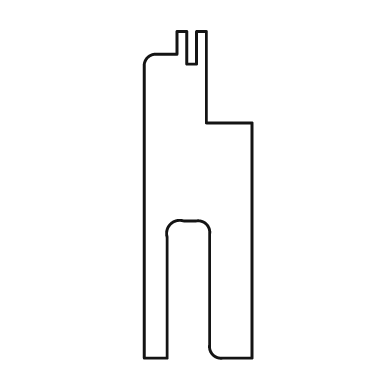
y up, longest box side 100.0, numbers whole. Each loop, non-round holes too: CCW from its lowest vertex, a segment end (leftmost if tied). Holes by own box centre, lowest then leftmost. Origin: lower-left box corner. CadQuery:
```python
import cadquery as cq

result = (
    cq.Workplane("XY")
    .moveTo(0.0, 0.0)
    .lineTo(7.0, 0.0)
    .lineTo(7.0, 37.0)
    .threePointArc((8.0, 41.0), (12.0, 42.0))
    .lineTo(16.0, 42.0)
    .threePointArc((19.0, 41.0), (20.0, 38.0))
    .lineTo(20.0, 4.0)
    .threePointArc((21.0, 1.0), (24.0, 0.0))
    .lineTo(33.0, 0.0)
    .lineTo(33.0, 72.0)
    .lineTo(19.0, 72.0)
    .lineTo(19.0, 100.0)
    .lineTo(16.0, 100.0)
    .lineTo(16.0, 90.0)
    .lineTo(13.0, 90.0)
    .lineTo(13.0, 100.0)
    .lineTo(10.0, 100.0)
    .lineTo(10.0, 93.0)
    .lineTo(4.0, 93.0)
    .threePointArc((1.0, 92.0), (0.0, 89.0))
    .close()
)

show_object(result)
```